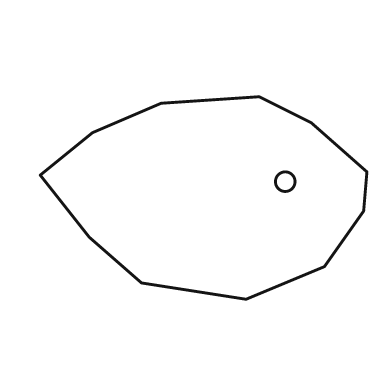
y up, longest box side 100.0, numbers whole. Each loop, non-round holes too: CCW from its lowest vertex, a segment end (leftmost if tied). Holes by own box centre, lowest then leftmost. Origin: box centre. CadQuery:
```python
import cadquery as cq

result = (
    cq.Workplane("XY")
    .moveTo(13.0, -31.0)
    .lineTo(37.0, -21.0)
    .lineTo(49.0, -4.0)
    .lineTo(50.0, 8.0)
    .lineTo(33.0, 23.0)
    .lineTo(17.0, 31.0)
    .lineTo(-13.0, 29.0)
    .lineTo(-34.0, 20.0)
    .lineTo(-50.0, 7.0)
    .lineTo(-35.0, -12.0)
    .lineTo(-19.0, -26.0)
    .close()
    .moveTo(25.0, 5.0)
    .circle(3.0)
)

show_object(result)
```